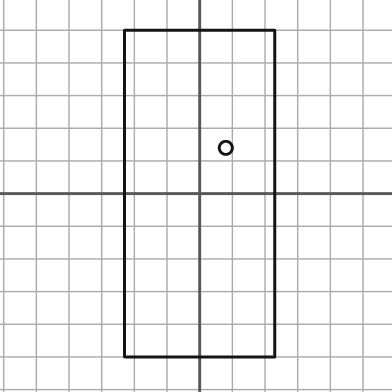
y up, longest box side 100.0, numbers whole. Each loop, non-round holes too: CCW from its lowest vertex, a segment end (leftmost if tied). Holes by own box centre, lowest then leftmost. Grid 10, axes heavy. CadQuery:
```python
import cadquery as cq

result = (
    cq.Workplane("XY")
    .moveTo(-23.0, -50.0)
    .lineTo(23.0, -50.0)
    .lineTo(23.0, 50.0)
    .lineTo(-23.0, 50.0)
    .close()
    .moveTo(8.0, 14.0)
    .circle(2.0)
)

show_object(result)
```